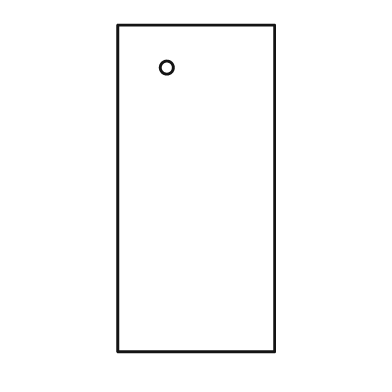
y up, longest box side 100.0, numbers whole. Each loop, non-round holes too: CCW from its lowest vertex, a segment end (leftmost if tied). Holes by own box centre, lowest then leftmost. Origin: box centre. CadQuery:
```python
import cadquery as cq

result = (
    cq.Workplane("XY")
    .moveTo(-24.0, -50.0)
    .lineTo(24.0, -50.0)
    .lineTo(24.0, 50.0)
    .lineTo(-24.0, 50.0)
    .close()
    .moveTo(-9.0, 37.0)
    .circle(2.0)
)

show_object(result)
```